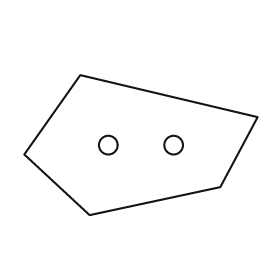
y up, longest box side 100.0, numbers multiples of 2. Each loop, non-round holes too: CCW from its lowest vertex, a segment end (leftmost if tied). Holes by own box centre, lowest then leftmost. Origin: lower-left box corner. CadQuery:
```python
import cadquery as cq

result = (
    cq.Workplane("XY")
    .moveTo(28.0, 0.0)
    .lineTo(84.0, 12.0)
    .lineTo(100.0, 42.0)
    .lineTo(24.0, 60.0)
    .lineTo(0.0, 26.0)
    .close()
    .moveTo(36.0, 30.0)
    .circle(4.0)
    .moveTo(64.0, 30.0)
    .circle(4.0)
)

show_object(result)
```